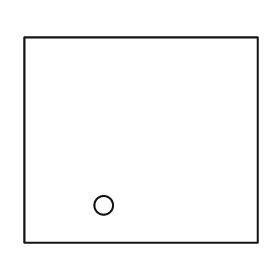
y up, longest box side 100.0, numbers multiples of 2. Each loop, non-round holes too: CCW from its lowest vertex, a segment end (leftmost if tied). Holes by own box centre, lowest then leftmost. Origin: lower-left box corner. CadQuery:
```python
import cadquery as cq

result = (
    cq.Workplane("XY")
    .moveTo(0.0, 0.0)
    .lineTo(100.0, 0.0)
    .lineTo(100.0, 88.0)
    .lineTo(0.0, 88.0)
    .close()
    .moveTo(34.0, 16.0)
    .circle(4.0)
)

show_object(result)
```